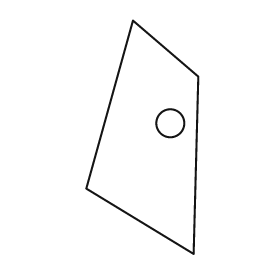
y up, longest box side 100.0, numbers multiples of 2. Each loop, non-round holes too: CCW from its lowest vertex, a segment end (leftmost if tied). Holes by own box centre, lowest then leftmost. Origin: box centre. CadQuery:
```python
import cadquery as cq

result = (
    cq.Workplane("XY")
    .moveTo(22.0, -50.0)
    .lineTo(24.0, 26.0)
    .lineTo(-4.0, 50.0)
    .lineTo(-24.0, -22.0)
    .close()
    .moveTo(12.0, 6.0)
    .circle(6.0)
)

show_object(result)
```